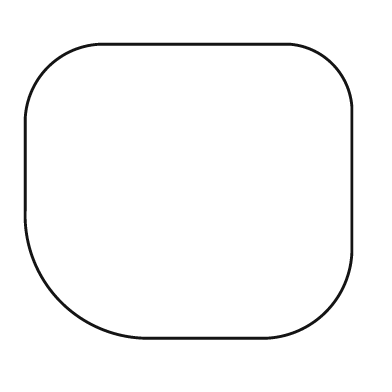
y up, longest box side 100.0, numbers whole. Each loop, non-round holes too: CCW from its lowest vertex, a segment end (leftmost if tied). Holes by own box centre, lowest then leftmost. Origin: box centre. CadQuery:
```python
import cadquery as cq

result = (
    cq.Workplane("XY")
    .moveTo(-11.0, -45.0)
    .lineTo(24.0, -45.0)
    .threePointArc((42.0, -37.0), (50.0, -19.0))
    .lineTo(50.0, 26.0)
    .threePointArc((44.0, 39.0), (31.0, 45.0))
    .lineTo(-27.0, 45.0)
    .threePointArc((-43.0, 38.0), (-50.0, 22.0))
    .lineTo(-50.0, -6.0)
    .threePointArc((-39.0, -34.0), (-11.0, -45.0))
    .close()
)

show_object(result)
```